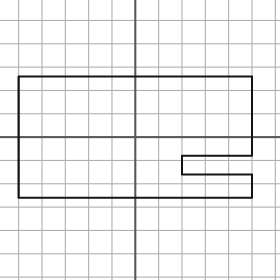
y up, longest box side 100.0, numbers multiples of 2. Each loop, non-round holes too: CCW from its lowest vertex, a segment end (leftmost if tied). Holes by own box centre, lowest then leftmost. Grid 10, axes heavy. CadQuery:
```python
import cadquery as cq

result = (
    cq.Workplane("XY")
    .moveTo(-50.0, -26.0)
    .lineTo(50.0, -26.0)
    .lineTo(50.0, -16.0)
    .lineTo(20.0, -16.0)
    .lineTo(20.0, -8.0)
    .lineTo(50.0, -8.0)
    .lineTo(50.0, 26.0)
    .lineTo(-50.0, 26.0)
    .close()
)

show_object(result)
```